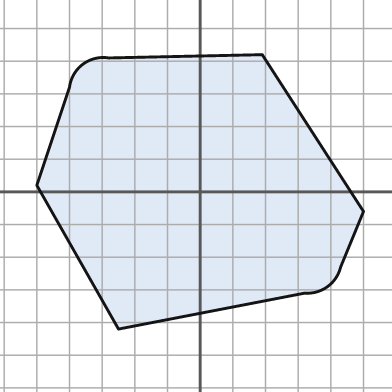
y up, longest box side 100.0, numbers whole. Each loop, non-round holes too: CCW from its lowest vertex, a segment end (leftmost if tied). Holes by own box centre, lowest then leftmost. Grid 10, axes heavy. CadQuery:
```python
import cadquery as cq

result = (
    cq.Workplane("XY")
    .moveTo(-25.0, -42.0)
    .lineTo(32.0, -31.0)
    .threePointArc((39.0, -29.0), (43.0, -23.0))
    .lineTo(50.0, -6.0)
    .lineTo(19.0, 42.0)
    .lineTo(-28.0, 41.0)
    .threePointArc((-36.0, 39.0), (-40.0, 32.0))
    .lineTo(-50.0, 2.0)
    .close()
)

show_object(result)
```